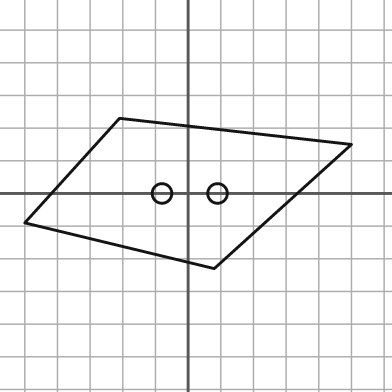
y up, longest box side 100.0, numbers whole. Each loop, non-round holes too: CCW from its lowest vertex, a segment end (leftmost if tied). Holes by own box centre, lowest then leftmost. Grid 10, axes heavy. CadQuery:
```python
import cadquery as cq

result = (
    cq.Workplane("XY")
    .moveTo(8.0, -23.0)
    .lineTo(50.0, 15.0)
    .lineTo(-21.0, 23.0)
    .lineTo(-50.0, -9.0)
    .close()
    .moveTo(-8.0, 0.0)
    .circle(3.0)
    .moveTo(9.0, 0.0)
    .circle(3.0)
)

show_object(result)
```